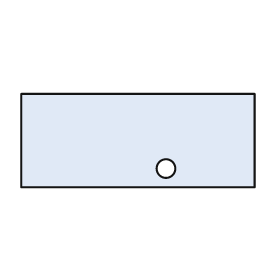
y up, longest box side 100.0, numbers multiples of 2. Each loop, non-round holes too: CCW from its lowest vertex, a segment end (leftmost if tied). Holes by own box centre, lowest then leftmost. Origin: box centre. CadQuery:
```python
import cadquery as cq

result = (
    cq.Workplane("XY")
    .moveTo(-50.0, -20.0)
    .lineTo(50.0, -20.0)
    .lineTo(50.0, 20.0)
    .lineTo(-50.0, 20.0)
    .close()
    .moveTo(12.0, -12.0)
    .circle(4.0)
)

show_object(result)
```